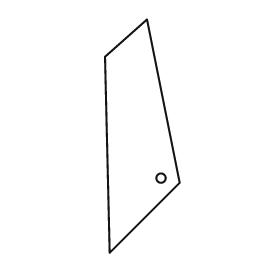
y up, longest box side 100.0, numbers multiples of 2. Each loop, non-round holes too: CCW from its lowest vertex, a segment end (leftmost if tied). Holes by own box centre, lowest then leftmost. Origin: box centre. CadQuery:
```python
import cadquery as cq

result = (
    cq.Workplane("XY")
    .moveTo(-14.0, -50.0)
    .lineTo(16.0, -20.0)
    .lineTo(2.0, 50.0)
    .lineTo(-16.0, 34.0)
    .close()
    .moveTo(8.0, -18.0)
    .circle(2.0)
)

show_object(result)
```